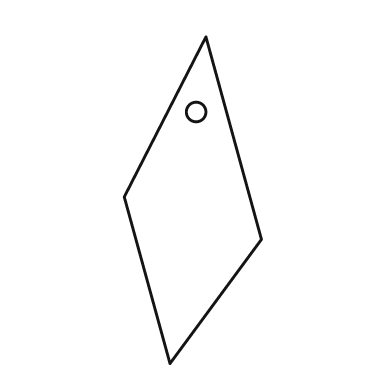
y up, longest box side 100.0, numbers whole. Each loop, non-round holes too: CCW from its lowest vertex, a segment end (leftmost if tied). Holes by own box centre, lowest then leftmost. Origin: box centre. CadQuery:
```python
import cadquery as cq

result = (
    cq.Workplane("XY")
    .moveTo(-7.0, -50.0)
    .lineTo(21.0, -12.0)
    .lineTo(4.0, 50.0)
    .lineTo(-21.0, 1.0)
    .close()
    .moveTo(1.0, 27.0)
    .circle(3.0)
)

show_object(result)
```